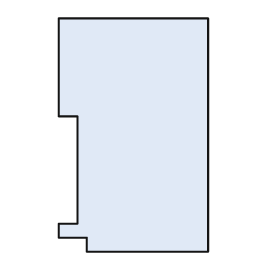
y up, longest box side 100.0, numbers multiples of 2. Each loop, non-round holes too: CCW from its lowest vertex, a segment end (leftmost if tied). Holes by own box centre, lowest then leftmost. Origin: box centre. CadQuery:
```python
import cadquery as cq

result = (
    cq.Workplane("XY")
    .moveTo(-20.0, -50.0)
    .lineTo(32.0, -50.0)
    .lineTo(32.0, 50.0)
    .lineTo(-32.0, 50.0)
    .lineTo(-32.0, 8.0)
    .lineTo(-24.0, 8.0)
    .lineTo(-24.0, -38.0)
    .lineTo(-32.0, -38.0)
    .lineTo(-32.0, -44.0)
    .lineTo(-20.0, -44.0)
    .close()
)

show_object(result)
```